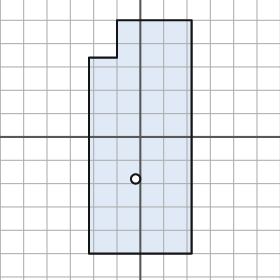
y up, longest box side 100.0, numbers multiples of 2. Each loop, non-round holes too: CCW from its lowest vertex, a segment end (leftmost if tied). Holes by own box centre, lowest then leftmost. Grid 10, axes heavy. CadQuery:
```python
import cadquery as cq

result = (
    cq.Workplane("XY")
    .moveTo(-22.0, -50.0)
    .lineTo(22.0, -50.0)
    .lineTo(22.0, 50.0)
    .lineTo(-10.0, 50.0)
    .lineTo(-10.0, 34.0)
    .lineTo(-22.0, 34.0)
    .close()
    .moveTo(-2.0, -18.0)
    .circle(2.0)
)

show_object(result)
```